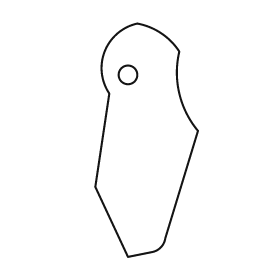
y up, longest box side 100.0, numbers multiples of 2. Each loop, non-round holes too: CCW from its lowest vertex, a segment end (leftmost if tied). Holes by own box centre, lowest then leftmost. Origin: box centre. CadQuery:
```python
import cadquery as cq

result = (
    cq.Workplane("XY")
    .moveTo(-8.0, -50.0)
    .lineTo(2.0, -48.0)
    .threePointArc((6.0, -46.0), (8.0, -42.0))
    .lineTo(22.0, 4.0)
    .threePointArc((14.0, 20.0), (14.0, 38.0))
    .threePointArc((6.0, 46.0), (-4.0, 50.0))
    .threePointArc((-18.0, 38.0), (-16.0, 20.0))
    .lineTo(-22.0, -20.0)
    .close()
    .moveTo(-8.0, 28.0)
    .circle(4.0)
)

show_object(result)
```